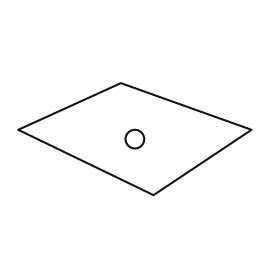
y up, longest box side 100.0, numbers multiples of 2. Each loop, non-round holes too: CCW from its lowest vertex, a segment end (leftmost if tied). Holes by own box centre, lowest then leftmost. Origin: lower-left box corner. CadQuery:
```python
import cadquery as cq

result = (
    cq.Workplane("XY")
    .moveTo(58.0, 0.0)
    .lineTo(100.0, 28.0)
    .lineTo(44.0, 48.0)
    .lineTo(0.0, 28.0)
    .close()
    .moveTo(50.0, 24.0)
    .circle(4.0)
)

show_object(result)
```